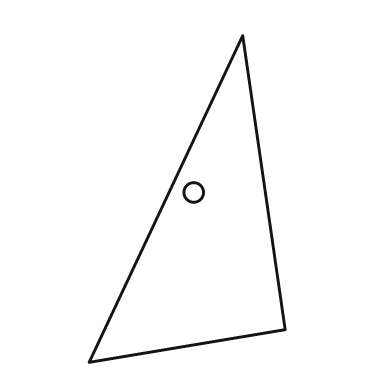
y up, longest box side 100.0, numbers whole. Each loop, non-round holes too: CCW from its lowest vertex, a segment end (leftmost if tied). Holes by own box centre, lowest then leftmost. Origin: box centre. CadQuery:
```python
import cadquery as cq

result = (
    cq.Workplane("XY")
    .moveTo(-30.0, -50.0)
    .lineTo(30.0, -40.0)
    .lineTo(17.0, 50.0)
    .close()
    .moveTo(2.0, 2.0)
    .circle(3.0)
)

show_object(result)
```